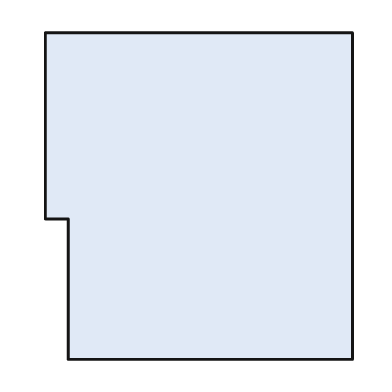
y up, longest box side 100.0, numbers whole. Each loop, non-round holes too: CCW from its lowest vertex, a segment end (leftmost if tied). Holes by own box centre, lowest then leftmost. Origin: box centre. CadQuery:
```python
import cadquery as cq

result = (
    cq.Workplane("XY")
    .moveTo(-40.0, -50.0)
    .lineTo(47.0, -50.0)
    .lineTo(47.0, 50.0)
    .lineTo(-47.0, 50.0)
    .lineTo(-47.0, -7.0)
    .lineTo(-40.0, -7.0)
    .close()
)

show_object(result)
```